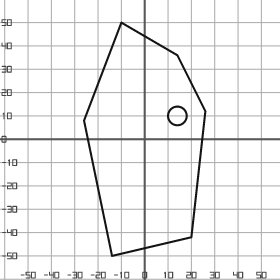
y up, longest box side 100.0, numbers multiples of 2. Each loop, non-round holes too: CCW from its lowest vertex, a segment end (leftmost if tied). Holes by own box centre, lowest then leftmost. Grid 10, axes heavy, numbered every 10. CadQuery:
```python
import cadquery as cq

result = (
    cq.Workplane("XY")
    .moveTo(-14.0, -50.0)
    .lineTo(20.0, -42.0)
    .lineTo(26.0, 12.0)
    .lineTo(14.0, 36.0)
    .lineTo(-10.0, 50.0)
    .lineTo(-26.0, 8.0)
    .close()
    .moveTo(14.0, 10.0)
    .circle(4.0)
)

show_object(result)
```